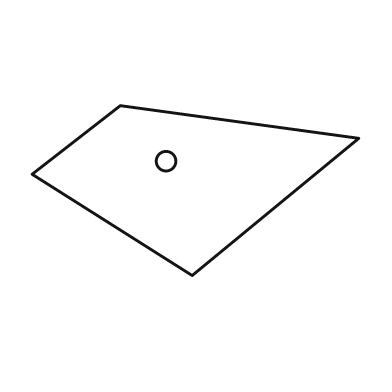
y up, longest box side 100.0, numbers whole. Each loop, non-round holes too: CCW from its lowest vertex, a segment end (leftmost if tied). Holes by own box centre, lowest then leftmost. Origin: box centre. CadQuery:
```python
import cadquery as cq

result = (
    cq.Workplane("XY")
    .moveTo(-1.0, -26.0)
    .lineTo(50.0, 16.0)
    .lineTo(-23.0, 26.0)
    .lineTo(-50.0, 5.0)
    .close()
    .moveTo(-9.0, 9.0)
    .circle(3.0)
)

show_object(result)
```